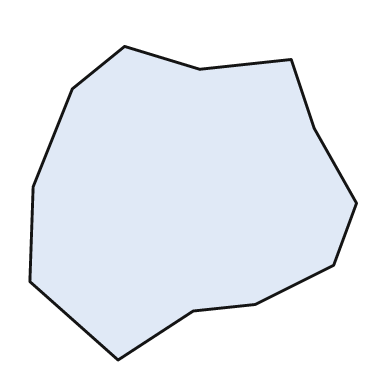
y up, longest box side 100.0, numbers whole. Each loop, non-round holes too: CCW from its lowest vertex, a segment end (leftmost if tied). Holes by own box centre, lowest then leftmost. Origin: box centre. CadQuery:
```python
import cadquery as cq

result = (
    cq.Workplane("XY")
    .moveTo(-23.0, -48.0)
    .lineTo(0.0, -33.0)
    .lineTo(19.0, -31.0)
    .lineTo(43.0, -19.0)
    .lineTo(50.0, 0.0)
    .lineTo(37.0, 23.0)
    .lineTo(30.0, 44.0)
    .lineTo(2.0, 41.0)
    .lineTo(-21.0, 48.0)
    .lineTo(-37.0, 35.0)
    .lineTo(-49.0, 5.0)
    .lineTo(-50.0, -24.0)
    .close()
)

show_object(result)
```